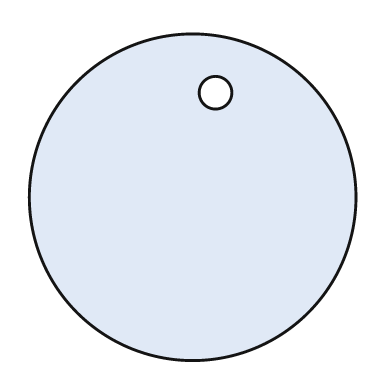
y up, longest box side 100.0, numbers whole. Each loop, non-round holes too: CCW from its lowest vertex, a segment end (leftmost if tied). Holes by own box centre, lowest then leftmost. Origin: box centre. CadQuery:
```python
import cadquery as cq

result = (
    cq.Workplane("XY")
    .moveTo(0.0, 0.0)
    .circle(50.0)
    .moveTo(7.0, 32.0)
    .circle(5.0)
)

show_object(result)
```